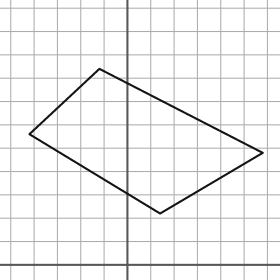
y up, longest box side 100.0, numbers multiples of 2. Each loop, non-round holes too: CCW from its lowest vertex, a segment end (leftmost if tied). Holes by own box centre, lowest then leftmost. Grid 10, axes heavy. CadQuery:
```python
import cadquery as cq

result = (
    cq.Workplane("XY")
    .moveTo(14.0, 22.0)
    .lineTo(58.0, 48.0)
    .lineTo(-12.0, 84.0)
    .lineTo(-42.0, 56.0)
    .close()
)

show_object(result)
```